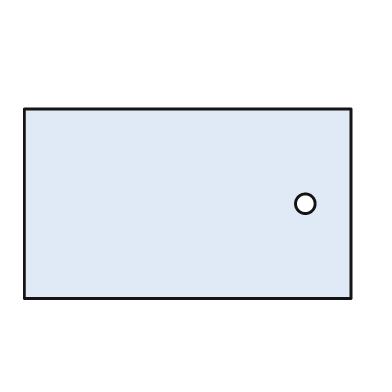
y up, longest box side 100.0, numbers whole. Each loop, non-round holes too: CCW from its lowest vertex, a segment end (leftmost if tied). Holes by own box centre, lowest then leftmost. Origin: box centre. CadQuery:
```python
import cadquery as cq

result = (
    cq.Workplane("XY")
    .moveTo(-50.0, -29.0)
    .lineTo(50.0, -29.0)
    .lineTo(50.0, 29.0)
    .lineTo(-50.0, 29.0)
    .close()
    .moveTo(36.0, 0.0)
    .circle(3.0)
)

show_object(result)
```